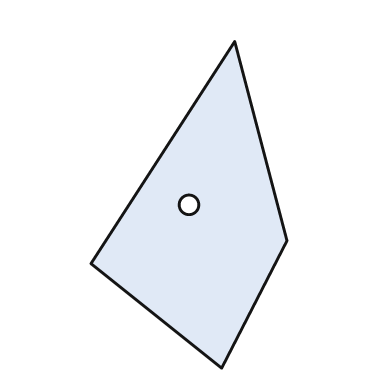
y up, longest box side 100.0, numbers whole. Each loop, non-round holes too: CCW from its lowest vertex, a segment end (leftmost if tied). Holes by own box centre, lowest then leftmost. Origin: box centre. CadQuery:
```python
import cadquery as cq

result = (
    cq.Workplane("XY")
    .moveTo(10.0, -50.0)
    .lineTo(30.0, -11.0)
    .lineTo(14.0, 50.0)
    .lineTo(-30.0, -18.0)
    .close()
    .moveTo(0.0, 0.0)
    .circle(3.0)
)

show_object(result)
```